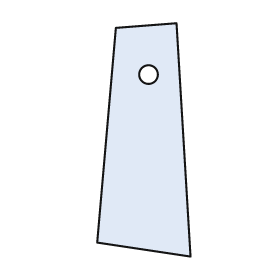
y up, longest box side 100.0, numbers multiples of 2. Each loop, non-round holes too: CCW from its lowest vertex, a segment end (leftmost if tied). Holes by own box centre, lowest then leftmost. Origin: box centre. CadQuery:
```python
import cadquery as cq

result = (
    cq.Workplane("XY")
    .moveTo(20.0, -50.0)
    .lineTo(14.0, 50.0)
    .lineTo(-12.0, 48.0)
    .lineTo(-20.0, -44.0)
    .close()
    .moveTo(2.0, 28.0)
    .circle(4.0)
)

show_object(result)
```